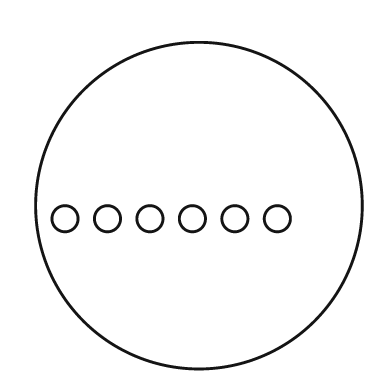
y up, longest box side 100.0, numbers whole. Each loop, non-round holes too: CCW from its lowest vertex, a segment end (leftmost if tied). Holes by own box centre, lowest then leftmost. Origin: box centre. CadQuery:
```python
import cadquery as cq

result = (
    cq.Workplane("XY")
    .moveTo(0.0, 0.0)
    .circle(50.0)
    .moveTo(-41.0, -4.0)
    .circle(4.0)
    .moveTo(-28.0, -4.0)
    .circle(4.0)
    .moveTo(-15.0, -4.0)
    .circle(4.0)
    .moveTo(-2.0, -4.0)
    .circle(4.0)
    .moveTo(11.0, -4.0)
    .circle(4.0)
    .moveTo(24.0, -4.0)
    .circle(4.0)
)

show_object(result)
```